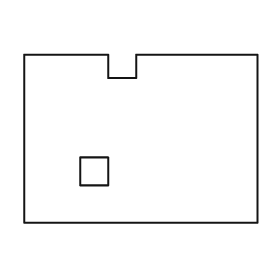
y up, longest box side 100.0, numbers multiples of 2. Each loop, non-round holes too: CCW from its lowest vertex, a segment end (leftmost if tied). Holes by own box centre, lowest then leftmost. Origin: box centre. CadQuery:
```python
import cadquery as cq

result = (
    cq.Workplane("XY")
    .moveTo(-50.0, -36.0)
    .lineTo(50.0, -36.0)
    .lineTo(50.0, 36.0)
    .lineTo(-2.0, 36.0)
    .lineTo(-2.0, 26.0)
    .lineTo(-14.0, 26.0)
    .lineTo(-14.0, 36.0)
    .lineTo(-50.0, 36.0)
    .close()
    .moveTo(-26.0, -20.0)
    .lineTo(-14.0, -20.0)
    .lineTo(-14.0, -8.0)
    .lineTo(-26.0, -8.0)
    .close()
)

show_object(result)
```